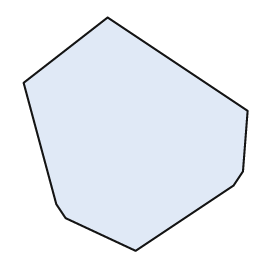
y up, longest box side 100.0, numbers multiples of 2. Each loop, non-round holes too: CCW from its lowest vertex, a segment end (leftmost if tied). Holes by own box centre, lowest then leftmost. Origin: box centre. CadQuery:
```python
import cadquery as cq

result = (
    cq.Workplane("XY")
    .moveTo(0.0, -50.0)
    .lineTo(42.0, -22.0)
    .lineTo(46.0, -16.0)
    .lineTo(48.0, 10.0)
    .lineTo(-12.0, 50.0)
    .lineTo(-48.0, 22.0)
    .lineTo(-34.0, -30.0)
    .lineTo(-30.0, -36.0)
    .close()
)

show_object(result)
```